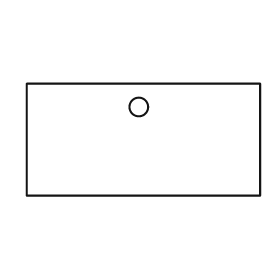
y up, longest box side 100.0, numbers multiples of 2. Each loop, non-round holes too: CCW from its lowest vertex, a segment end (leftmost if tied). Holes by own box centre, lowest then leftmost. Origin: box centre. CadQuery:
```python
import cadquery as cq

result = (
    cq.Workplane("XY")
    .moveTo(-50.0, -24.0)
    .lineTo(50.0, -24.0)
    .lineTo(50.0, 24.0)
    .lineTo(-50.0, 24.0)
    .close()
    .moveTo(-2.0, 14.0)
    .circle(4.0)
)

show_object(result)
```